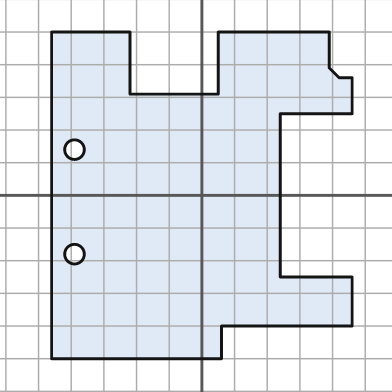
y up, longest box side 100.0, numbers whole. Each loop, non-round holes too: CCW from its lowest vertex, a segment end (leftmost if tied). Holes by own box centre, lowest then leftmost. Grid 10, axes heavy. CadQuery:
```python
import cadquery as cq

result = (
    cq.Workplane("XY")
    .moveTo(-46.0, -50.0)
    .lineTo(6.0, -50.0)
    .lineTo(6.0, -40.0)
    .lineTo(46.0, -40.0)
    .lineTo(46.0, -25.0)
    .lineTo(24.0, -25.0)
    .lineTo(24.0, 25.0)
    .lineTo(46.0, 25.0)
    .lineTo(46.0, 36.0)
    .lineTo(42.0, 36.0)
    .lineTo(39.0, 39.0)
    .lineTo(39.0, 50.0)
    .lineTo(5.0, 50.0)
    .lineTo(5.0, 31.0)
    .lineTo(-22.0, 31.0)
    .lineTo(-22.0, 50.0)
    .lineTo(-46.0, 50.0)
    .close()
    .moveTo(-39.0, -18.0)
    .circle(3.0)
    .moveTo(-39.0, 14.0)
    .circle(3.0)
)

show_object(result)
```